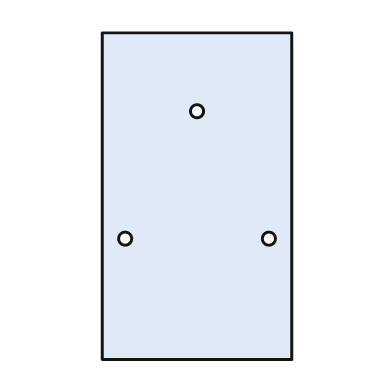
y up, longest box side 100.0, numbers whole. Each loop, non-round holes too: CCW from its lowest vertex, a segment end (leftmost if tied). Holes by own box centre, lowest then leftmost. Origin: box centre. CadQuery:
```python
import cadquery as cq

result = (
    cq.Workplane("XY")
    .moveTo(-29.0, -50.0)
    .lineTo(29.0, -50.0)
    .lineTo(29.0, 50.0)
    .lineTo(-29.0, 50.0)
    .close()
    .moveTo(-22.0, -13.0)
    .circle(2.0)
    .moveTo(22.0, -13.0)
    .circle(2.0)
    .moveTo(0.0, 26.0)
    .circle(2.0)
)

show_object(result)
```